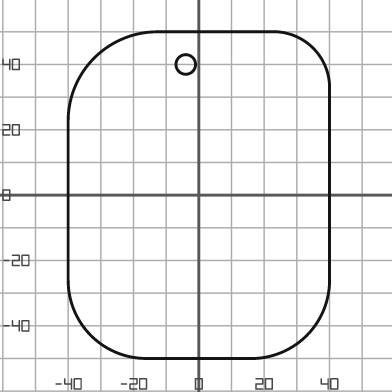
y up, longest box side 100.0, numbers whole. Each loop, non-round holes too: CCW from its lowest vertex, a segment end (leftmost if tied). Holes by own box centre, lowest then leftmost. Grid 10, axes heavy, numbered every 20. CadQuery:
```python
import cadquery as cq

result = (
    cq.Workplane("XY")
    .moveTo(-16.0, -50.0)
    .lineTo(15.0, -50.0)
    .threePointArc((33.0, -43.0), (40.0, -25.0))
    .lineTo(40.0, 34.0)
    .threePointArc((35.0, 45.0), (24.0, 50.0))
    .lineTo(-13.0, 50.0)
    .threePointArc((-32.0, 42.0), (-40.0, 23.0))
    .lineTo(-40.0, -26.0)
    .threePointArc((-33.0, -43.0), (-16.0, -50.0))
    .close()
    .moveTo(-4.0, 40.0)
    .circle(3.0)
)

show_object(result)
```